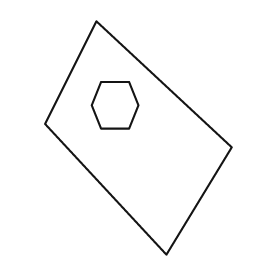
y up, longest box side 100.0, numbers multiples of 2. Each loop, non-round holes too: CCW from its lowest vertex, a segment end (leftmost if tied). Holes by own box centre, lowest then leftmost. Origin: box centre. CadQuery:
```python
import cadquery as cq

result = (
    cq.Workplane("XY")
    .moveTo(12.0, -50.0)
    .lineTo(40.0, -4.0)
    .lineTo(-18.0, 50.0)
    .lineTo(-40.0, 6.0)
    .close()
    .moveTo(-16.0, 4.0)
    .lineTo(-4.0, 4.0)
    .lineTo(0.0, 14.0)
    .lineTo(-4.0, 24.0)
    .lineTo(-16.0, 24.0)
    .lineTo(-20.0, 14.0)
    .close()
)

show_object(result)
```